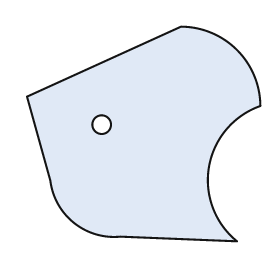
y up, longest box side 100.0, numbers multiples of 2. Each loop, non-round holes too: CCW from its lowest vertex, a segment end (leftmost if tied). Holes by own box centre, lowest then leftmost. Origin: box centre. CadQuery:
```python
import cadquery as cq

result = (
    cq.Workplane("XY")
    .moveTo(40.0, -46.0)
    .threePointArc((28.0, -14.0), (50.0, 12.0))
    .threePointArc((40.0, 36.0), (16.0, 46.0))
    .lineTo(-50.0, 16.0)
    .lineTo(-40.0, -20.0)
    .threePointArc((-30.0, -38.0), (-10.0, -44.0))
    .close()
    .moveTo(-18.0, 4.0)
    .circle(4.0)
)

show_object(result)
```